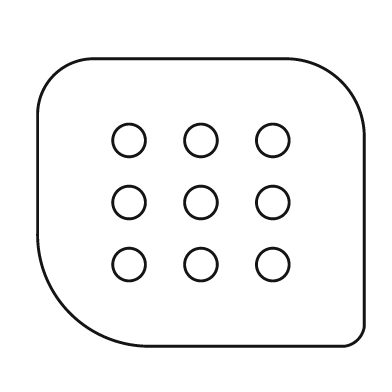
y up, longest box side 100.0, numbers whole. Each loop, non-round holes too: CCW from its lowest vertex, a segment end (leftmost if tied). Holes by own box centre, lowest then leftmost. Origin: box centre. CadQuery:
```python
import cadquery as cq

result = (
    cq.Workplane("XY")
    .moveTo(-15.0, -44.0)
    .lineTo(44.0, -44.0)
    .threePointArc((48.0, -42.0), (50.0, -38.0))
    .lineTo(50.0, 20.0)
    .threePointArc((43.0, 37.0), (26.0, 44.0))
    .lineTo(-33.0, 44.0)
    .threePointArc((-45.0, 39.0), (-50.0, 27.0))
    .lineTo(-50.0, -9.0)
    .threePointArc((-40.0, -34.0), (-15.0, -44.0))
    .close()
    .moveTo(-22.0, -19.0)
    .circle(5.0)
    .moveTo(0.0, -19.0)
    .circle(5.0)
    .moveTo(22.0, -19.0)
    .circle(5.0)
    .moveTo(-22.0, 0.0)
    .circle(5.0)
    .moveTo(0.0, 0.0)
    .circle(5.0)
    .moveTo(22.0, 0.0)
    .circle(5.0)
    .moveTo(-22.0, 19.0)
    .circle(5.0)
    .moveTo(0.0, 19.0)
    .circle(5.0)
    .moveTo(22.0, 19.0)
    .circle(5.0)
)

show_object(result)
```